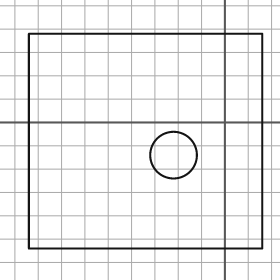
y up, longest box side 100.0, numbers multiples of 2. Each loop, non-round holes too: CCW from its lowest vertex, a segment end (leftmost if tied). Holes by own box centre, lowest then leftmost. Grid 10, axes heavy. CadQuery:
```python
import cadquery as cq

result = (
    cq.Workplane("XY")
    .moveTo(-84.0, -54.0)
    .lineTo(16.0, -54.0)
    .lineTo(16.0, 38.0)
    .lineTo(-84.0, 38.0)
    .close()
    .moveTo(-22.0, -14.0)
    .circle(10.0)
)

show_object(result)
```